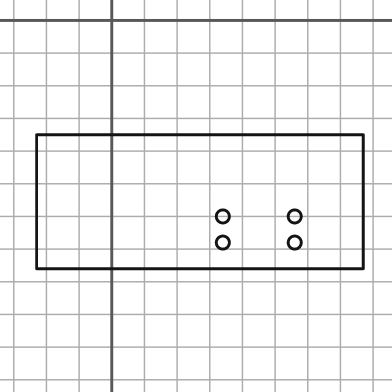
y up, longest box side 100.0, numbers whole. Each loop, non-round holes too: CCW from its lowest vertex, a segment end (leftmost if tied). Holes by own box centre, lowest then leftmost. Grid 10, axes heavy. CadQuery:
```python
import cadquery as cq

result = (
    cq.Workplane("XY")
    .moveTo(-23.0, -76.0)
    .lineTo(77.0, -76.0)
    .lineTo(77.0, -35.0)
    .lineTo(-23.0, -35.0)
    .close()
    .moveTo(34.0, -68.0)
    .circle(2.0)
    .moveTo(56.0, -68.0)
    .circle(2.0)
    .moveTo(34.0, -60.0)
    .circle(2.0)
    .moveTo(56.0, -60.0)
    .circle(2.0)
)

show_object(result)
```